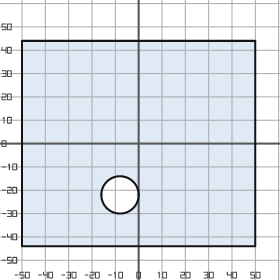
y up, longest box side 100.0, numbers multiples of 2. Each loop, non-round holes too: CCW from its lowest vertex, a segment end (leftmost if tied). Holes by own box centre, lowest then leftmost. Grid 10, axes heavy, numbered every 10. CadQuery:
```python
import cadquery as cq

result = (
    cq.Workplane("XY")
    .moveTo(-50.0, -44.0)
    .lineTo(50.0, -44.0)
    .lineTo(50.0, 44.0)
    .lineTo(-50.0, 44.0)
    .close()
    .moveTo(-8.0, -22.0)
    .circle(8.0)
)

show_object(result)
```